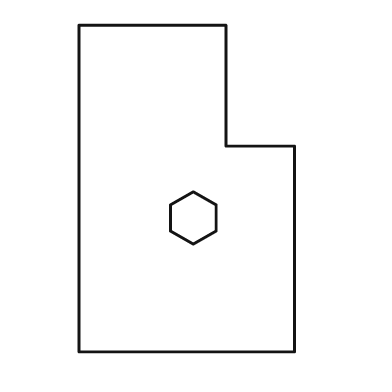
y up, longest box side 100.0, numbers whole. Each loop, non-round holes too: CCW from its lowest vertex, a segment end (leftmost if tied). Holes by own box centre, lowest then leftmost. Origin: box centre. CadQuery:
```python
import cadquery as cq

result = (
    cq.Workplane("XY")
    .moveTo(-33.0, -50.0)
    .lineTo(33.0, -50.0)
    .lineTo(33.0, 13.0)
    .lineTo(12.0, 13.0)
    .lineTo(12.0, 50.0)
    .lineTo(-33.0, 50.0)
    .close()
    .moveTo(2.0, -17.0)
    .lineTo(9.0, -13.0)
    .lineTo(9.0, -5.0)
    .lineTo(2.0, -1.0)
    .lineTo(-5.0, -5.0)
    .lineTo(-5.0, -13.0)
    .close()
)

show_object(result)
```